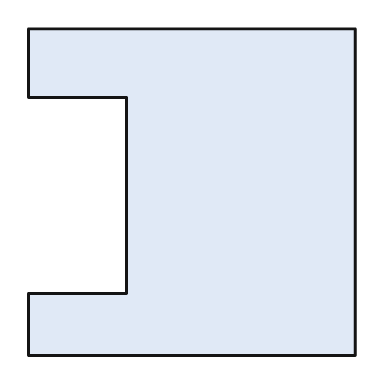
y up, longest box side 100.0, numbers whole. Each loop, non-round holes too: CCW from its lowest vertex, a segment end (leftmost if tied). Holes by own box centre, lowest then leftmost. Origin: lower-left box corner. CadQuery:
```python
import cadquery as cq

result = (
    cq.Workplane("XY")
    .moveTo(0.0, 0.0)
    .lineTo(100.0, 0.0)
    .lineTo(100.0, 100.0)
    .lineTo(0.0, 100.0)
    .lineTo(0.0, 79.0)
    .lineTo(30.0, 79.0)
    .lineTo(30.0, 19.0)
    .lineTo(0.0, 19.0)
    .close()
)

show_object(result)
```